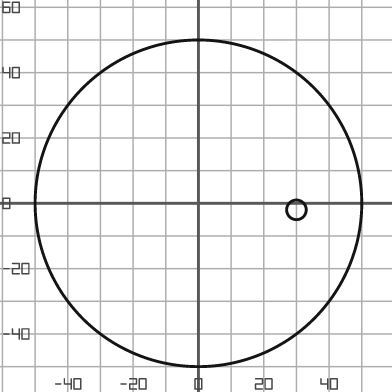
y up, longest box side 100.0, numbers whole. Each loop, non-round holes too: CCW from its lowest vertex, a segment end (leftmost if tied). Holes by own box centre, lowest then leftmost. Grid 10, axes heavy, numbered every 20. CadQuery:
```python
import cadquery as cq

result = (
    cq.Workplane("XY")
    .moveTo(0.0, 0.0)
    .circle(50.0)
    .moveTo(30.0, -2.0)
    .circle(3.0)
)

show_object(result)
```